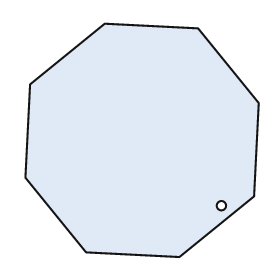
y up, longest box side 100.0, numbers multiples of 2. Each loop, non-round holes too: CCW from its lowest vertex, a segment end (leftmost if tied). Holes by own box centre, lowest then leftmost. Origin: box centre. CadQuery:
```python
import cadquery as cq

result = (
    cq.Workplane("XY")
    .moveTo(16.0, -50.0)
    .lineTo(48.0, -24.0)
    .lineTo(50.0, 16.0)
    .lineTo(24.0, 48.0)
    .lineTo(-16.0, 50.0)
    .lineTo(-48.0, 24.0)
    .lineTo(-50.0, -16.0)
    .lineTo(-24.0, -48.0)
    .close()
    .moveTo(34.0, -28.0)
    .circle(2.0)
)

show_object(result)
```